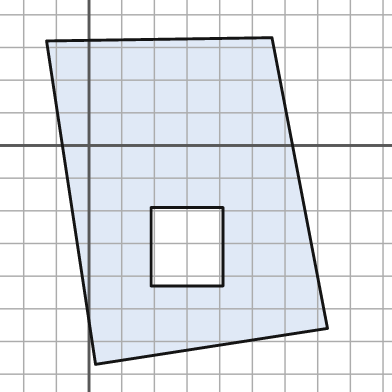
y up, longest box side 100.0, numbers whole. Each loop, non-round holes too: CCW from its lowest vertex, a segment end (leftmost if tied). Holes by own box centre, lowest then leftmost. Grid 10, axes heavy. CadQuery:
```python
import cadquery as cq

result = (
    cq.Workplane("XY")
    .moveTo(2.0, -67.0)
    .lineTo(73.0, -56.0)
    .lineTo(56.0, 33.0)
    .lineTo(-13.0, 32.0)
    .close()
    .moveTo(19.0, -43.0)
    .lineTo(41.0, -43.0)
    .lineTo(41.0, -19.0)
    .lineTo(19.0, -19.0)
    .close()
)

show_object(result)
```